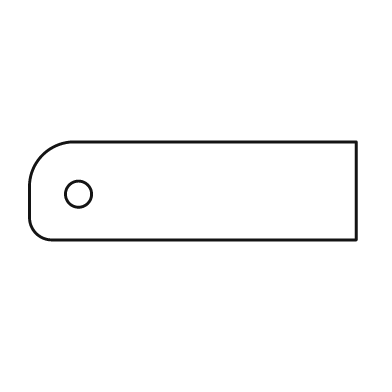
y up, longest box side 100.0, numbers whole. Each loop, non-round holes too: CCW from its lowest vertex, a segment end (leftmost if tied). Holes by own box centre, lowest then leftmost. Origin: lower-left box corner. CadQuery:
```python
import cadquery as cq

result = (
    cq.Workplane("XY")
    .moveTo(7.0, 0.0)
    .lineTo(100.0, 0.0)
    .lineTo(100.0, 30.0)
    .lineTo(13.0, 30.0)
    .threePointArc((4.0, 26.0), (0.0, 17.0))
    .lineTo(0.0, 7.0)
    .threePointArc((2.0, 2.0), (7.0, 0.0))
    .close()
    .moveTo(15.0, 14.0)
    .circle(4.0)
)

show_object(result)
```